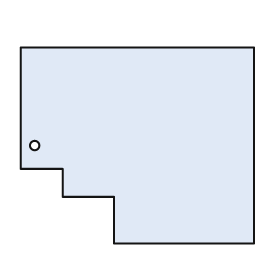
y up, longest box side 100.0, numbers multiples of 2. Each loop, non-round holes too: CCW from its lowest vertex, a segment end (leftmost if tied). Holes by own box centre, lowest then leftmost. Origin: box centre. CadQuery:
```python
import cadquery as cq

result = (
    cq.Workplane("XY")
    .moveTo(-10.0, -42.0)
    .lineTo(50.0, -42.0)
    .lineTo(50.0, 42.0)
    .lineTo(-50.0, 42.0)
    .lineTo(-50.0, -10.0)
    .lineTo(-32.0, -10.0)
    .lineTo(-32.0, -22.0)
    .lineTo(-10.0, -22.0)
    .close()
    .moveTo(-44.0, 0.0)
    .circle(2.0)
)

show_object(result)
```